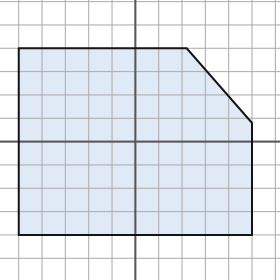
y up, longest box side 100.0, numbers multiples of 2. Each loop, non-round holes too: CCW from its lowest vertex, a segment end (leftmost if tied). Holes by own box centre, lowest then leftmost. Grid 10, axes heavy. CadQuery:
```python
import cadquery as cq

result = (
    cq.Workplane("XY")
    .moveTo(-50.0, -40.0)
    .lineTo(50.0, -40.0)
    .lineTo(50.0, 8.0)
    .lineTo(22.0, 40.0)
    .lineTo(-50.0, 40.0)
    .close()
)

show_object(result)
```